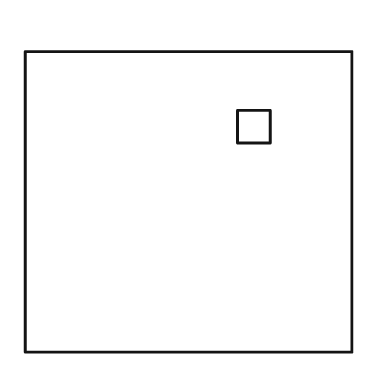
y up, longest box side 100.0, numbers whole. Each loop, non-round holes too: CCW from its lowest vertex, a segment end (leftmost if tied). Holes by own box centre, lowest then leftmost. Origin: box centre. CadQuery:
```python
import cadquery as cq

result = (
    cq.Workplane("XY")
    .moveTo(-50.0, -46.0)
    .lineTo(50.0, -46.0)
    .lineTo(50.0, 46.0)
    .lineTo(-50.0, 46.0)
    .close()
    .moveTo(15.0, 18.0)
    .lineTo(25.0, 18.0)
    .lineTo(25.0, 28.0)
    .lineTo(15.0, 28.0)
    .close()
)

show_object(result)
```